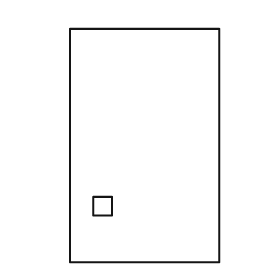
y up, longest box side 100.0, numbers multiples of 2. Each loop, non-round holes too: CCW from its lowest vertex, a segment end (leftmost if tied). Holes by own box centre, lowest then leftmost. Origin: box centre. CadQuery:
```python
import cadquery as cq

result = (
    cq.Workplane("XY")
    .moveTo(-32.0, -50.0)
    .lineTo(32.0, -50.0)
    .lineTo(32.0, 50.0)
    .lineTo(-32.0, 50.0)
    .close()
    .moveTo(-22.0, -30.0)
    .lineTo(-14.0, -30.0)
    .lineTo(-14.0, -22.0)
    .lineTo(-22.0, -22.0)
    .close()
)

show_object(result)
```